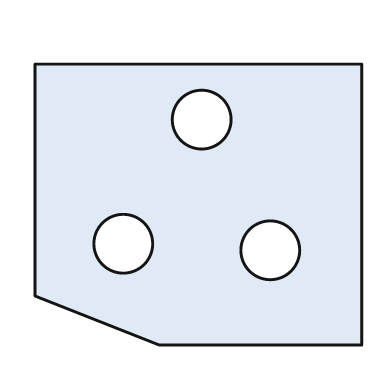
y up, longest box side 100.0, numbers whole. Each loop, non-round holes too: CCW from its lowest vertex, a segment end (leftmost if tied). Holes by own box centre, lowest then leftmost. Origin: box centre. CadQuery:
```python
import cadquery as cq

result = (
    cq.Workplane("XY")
    .moveTo(-12.0, -43.0)
    .lineTo(50.0, -43.0)
    .lineTo(50.0, 43.0)
    .lineTo(-50.0, 43.0)
    .lineTo(-50.0, -28.0)
    .close()
    .moveTo(22.0, -14.0)
    .circle(9.0)
    .moveTo(-23.0, -12.0)
    .circle(9.0)
    .moveTo(1.0, 26.0)
    .circle(9.0)
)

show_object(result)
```